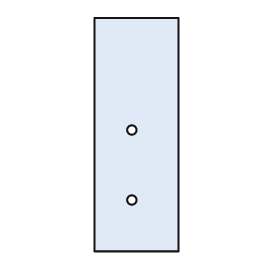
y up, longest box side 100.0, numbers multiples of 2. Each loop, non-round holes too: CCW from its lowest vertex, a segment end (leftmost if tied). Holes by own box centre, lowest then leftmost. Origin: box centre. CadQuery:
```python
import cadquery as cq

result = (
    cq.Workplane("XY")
    .moveTo(-18.0, -50.0)
    .lineTo(18.0, -50.0)
    .lineTo(18.0, 50.0)
    .lineTo(-18.0, 50.0)
    .close()
    .moveTo(-2.0, -28.0)
    .circle(2.0)
    .moveTo(-2.0, 2.0)
    .circle(2.0)
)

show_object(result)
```